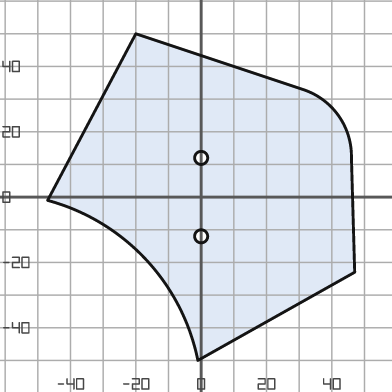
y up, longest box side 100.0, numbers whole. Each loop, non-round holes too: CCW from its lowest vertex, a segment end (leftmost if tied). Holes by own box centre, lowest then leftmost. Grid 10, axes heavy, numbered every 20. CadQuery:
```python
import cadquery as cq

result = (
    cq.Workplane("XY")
    .moveTo(-1.0, -50.0)
    .lineTo(47.0, -23.0)
    .lineTo(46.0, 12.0)
    .threePointArc((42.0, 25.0), (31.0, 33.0))
    .lineTo(-20.0, 50.0)
    .lineTo(-47.0, -1.0)
    .threePointArc((-17.0, -19.0), (-1.0, -50.0))
    .close()
    .moveTo(0.0, -12.0)
    .circle(2.0)
    .moveTo(0.0, 12.0)
    .circle(2.0)
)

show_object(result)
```